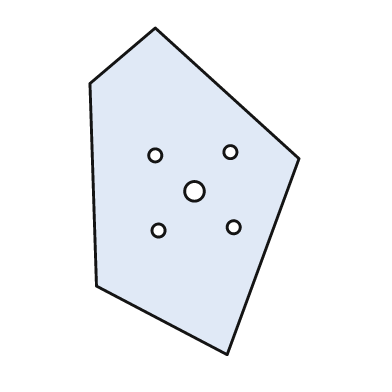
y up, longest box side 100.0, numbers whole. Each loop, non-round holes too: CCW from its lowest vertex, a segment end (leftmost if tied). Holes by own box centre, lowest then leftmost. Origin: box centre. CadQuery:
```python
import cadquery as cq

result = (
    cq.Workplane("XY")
    .moveTo(10.0, -50.0)
    .lineTo(32.0, 10.0)
    .lineTo(-12.0, 50.0)
    .lineTo(-32.0, 33.0)
    .lineTo(-30.0, -29.0)
    .close()
    .moveTo(-11.0, -12.0)
    .circle(2.0)
    .moveTo(12.0, -11.0)
    .circle(2.0)
    .moveTo(0.0, 0.0)
    .circle(3.0)
    .moveTo(-12.0, 11.0)
    .circle(2.0)
    .moveTo(11.0, 12.0)
    .circle(2.0)
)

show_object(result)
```